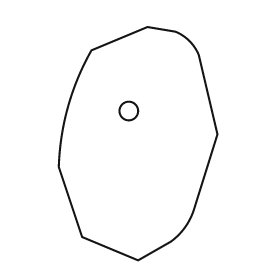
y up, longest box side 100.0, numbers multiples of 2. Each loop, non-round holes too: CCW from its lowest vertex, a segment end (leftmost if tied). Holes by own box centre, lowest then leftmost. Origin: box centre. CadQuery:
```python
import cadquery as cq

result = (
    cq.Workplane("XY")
    .moveTo(0.0, -50.0)
    .lineTo(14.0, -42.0)
    .threePointArc((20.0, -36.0), (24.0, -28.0))
    .lineTo(34.0, 4.0)
    .lineTo(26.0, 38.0)
    .threePointArc((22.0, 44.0), (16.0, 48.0))
    .lineTo(4.0, 50.0)
    .lineTo(-20.0, 40.0)
    .threePointArc((-30.0, 16.0), (-34.0, -10.0))
    .lineTo(-24.0, -40.0)
    .close()
    .moveTo(-4.0, 14.0)
    .circle(4.0)
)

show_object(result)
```